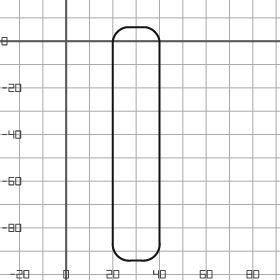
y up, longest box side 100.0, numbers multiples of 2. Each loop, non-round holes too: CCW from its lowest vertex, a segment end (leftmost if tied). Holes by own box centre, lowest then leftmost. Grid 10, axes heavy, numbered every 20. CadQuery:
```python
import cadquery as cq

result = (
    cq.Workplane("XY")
    .moveTo(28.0, -94.0)
    .lineTo(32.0, -94.0)
    .threePointArc((38.0, -92.0), (40.0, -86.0))
    .lineTo(40.0, 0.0)
    .threePointArc((38.0, 4.0), (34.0, 6.0))
    .lineTo(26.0, 6.0)
    .threePointArc((22.0, 4.0), (20.0, 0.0))
    .lineTo(20.0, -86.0)
    .threePointArc((22.0, -92.0), (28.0, -94.0))
    .close()
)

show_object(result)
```